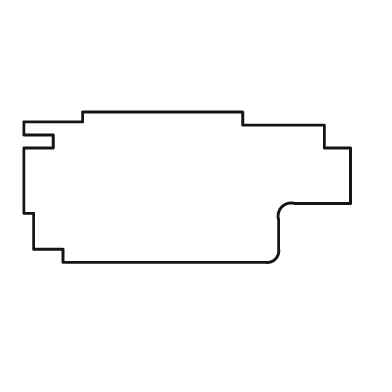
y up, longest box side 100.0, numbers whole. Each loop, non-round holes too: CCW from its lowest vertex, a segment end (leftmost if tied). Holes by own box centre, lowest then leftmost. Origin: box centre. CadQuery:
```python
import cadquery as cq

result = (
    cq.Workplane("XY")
    .moveTo(-38.0, -23.0)
    .lineTo(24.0, -23.0)
    .threePointArc((27.0, -22.0), (28.0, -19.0))
    .lineTo(28.0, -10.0)
    .threePointArc((29.0, -6.0), (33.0, -5.0))
    .lineTo(50.0, -5.0)
    .lineTo(50.0, 12.0)
    .lineTo(42.0, 12.0)
    .lineTo(42.0, 19.0)
    .lineTo(17.0, 19.0)
    .lineTo(17.0, 23.0)
    .lineTo(-32.0, 23.0)
    .lineTo(-32.0, 20.0)
    .lineTo(-50.0, 20.0)
    .lineTo(-50.0, 16.0)
    .lineTo(-41.0, 16.0)
    .lineTo(-41.0, 12.0)
    .lineTo(-50.0, 12.0)
    .lineTo(-50.0, -8.0)
    .lineTo(-47.0, -8.0)
    .lineTo(-47.0, -19.0)
    .lineTo(-38.0, -19.0)
    .close()
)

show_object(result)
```